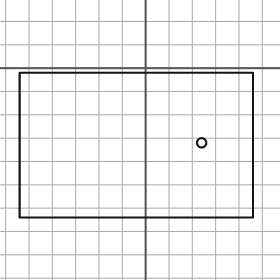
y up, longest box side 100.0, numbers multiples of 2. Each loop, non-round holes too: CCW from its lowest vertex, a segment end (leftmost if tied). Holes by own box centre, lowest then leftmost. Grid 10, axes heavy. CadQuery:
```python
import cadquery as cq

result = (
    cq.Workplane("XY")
    .moveTo(-54.0, -64.0)
    .lineTo(46.0, -64.0)
    .lineTo(46.0, -2.0)
    .lineTo(-54.0, -2.0)
    .close()
    .moveTo(24.0, -32.0)
    .circle(2.0)
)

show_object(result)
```